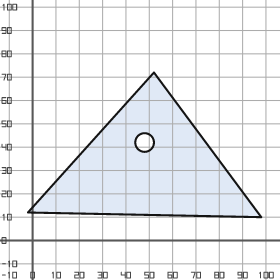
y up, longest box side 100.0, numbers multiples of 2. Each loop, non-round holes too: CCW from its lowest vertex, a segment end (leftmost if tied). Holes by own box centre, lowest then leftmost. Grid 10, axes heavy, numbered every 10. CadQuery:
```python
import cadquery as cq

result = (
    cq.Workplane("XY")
    .moveTo(98.0, 10.0)
    .lineTo(52.0, 72.0)
    .lineTo(-2.0, 12.0)
    .close()
    .moveTo(48.0, 42.0)
    .circle(4.0)
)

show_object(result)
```